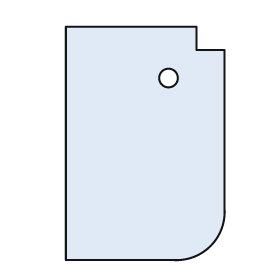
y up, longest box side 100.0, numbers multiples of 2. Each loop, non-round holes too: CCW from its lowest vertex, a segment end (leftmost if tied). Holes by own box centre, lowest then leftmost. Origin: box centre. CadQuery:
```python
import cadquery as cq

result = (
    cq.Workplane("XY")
    .moveTo(-34.0, -50.0)
    .lineTo(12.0, -50.0)
    .threePointArc((28.0, -44.0), (34.0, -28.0))
    .lineTo(34.0, 40.0)
    .lineTo(22.0, 40.0)
    .lineTo(22.0, 50.0)
    .lineTo(-34.0, 50.0)
    .close()
    .moveTo(10.0, 28.0)
    .circle(4.0)
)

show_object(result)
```